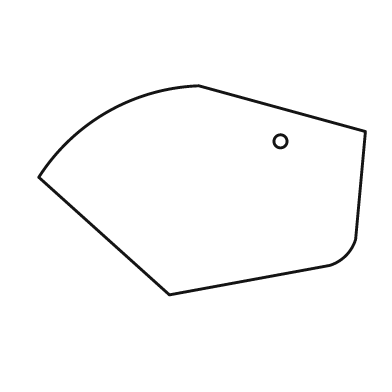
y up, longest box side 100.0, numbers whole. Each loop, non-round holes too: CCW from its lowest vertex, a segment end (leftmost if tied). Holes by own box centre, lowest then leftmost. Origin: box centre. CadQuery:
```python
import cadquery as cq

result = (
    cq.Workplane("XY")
    .moveTo(-10.0, -32.0)
    .lineTo(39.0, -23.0)
    .threePointArc((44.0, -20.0), (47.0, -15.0))
    .lineTo(50.0, 18.0)
    .lineTo(-1.0, 32.0)
    .threePointArc((-29.0, 24.0), (-50.0, 4.0))
    .close()
    .moveTo(24.0, 15.0)
    .circle(2.0)
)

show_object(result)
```